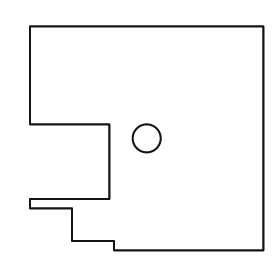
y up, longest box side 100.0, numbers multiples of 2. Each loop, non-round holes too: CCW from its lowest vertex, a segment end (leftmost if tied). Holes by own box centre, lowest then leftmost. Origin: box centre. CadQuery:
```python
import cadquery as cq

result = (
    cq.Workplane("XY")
    .moveTo(-14.0, -48.0)
    .lineTo(50.0, -48.0)
    .lineTo(50.0, 48.0)
    .lineTo(-50.0, 48.0)
    .lineTo(-50.0, 6.0)
    .lineTo(-16.0, 6.0)
    .lineTo(-16.0, -26.0)
    .lineTo(-50.0, -26.0)
    .lineTo(-50.0, -30.0)
    .lineTo(-32.0, -30.0)
    .lineTo(-32.0, -44.0)
    .lineTo(-14.0, -44.0)
    .close()
    .moveTo(0.0, 0.0)
    .circle(6.0)
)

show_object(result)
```